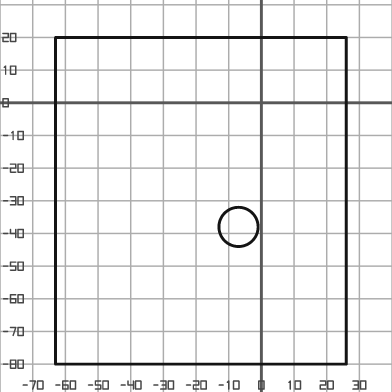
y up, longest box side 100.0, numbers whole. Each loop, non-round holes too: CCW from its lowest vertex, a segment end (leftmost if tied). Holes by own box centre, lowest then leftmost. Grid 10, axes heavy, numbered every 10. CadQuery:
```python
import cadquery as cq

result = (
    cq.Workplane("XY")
    .moveTo(-63.0, -80.0)
    .lineTo(26.0, -80.0)
    .lineTo(26.0, 20.0)
    .lineTo(-63.0, 20.0)
    .close()
    .moveTo(-7.0, -38.0)
    .circle(6.0)
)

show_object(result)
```